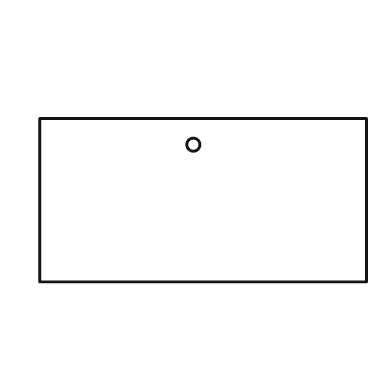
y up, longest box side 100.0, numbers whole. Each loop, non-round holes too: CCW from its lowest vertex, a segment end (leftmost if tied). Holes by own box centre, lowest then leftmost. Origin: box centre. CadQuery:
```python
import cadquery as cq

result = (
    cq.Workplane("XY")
    .moveTo(-50.0, -25.0)
    .lineTo(50.0, -25.0)
    .lineTo(50.0, 25.0)
    .lineTo(-50.0, 25.0)
    .close()
    .moveTo(-3.0, 17.0)
    .circle(2.0)
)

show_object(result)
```